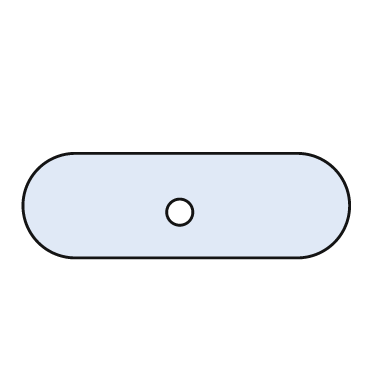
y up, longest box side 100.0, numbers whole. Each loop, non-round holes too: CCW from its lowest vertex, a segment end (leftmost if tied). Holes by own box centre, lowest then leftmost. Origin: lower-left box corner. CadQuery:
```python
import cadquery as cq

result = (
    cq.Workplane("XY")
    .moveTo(16.0, 0.0)
    .lineTo(84.0, 0.0)
    .threePointArc((100.0, 16.0), (84.0, 32.0))
    .lineTo(16.0, 32.0)
    .threePointArc((0.0, 16.0), (16.0, 0.0))
    .close()
    .moveTo(48.0, 14.0)
    .circle(4.0)
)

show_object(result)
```